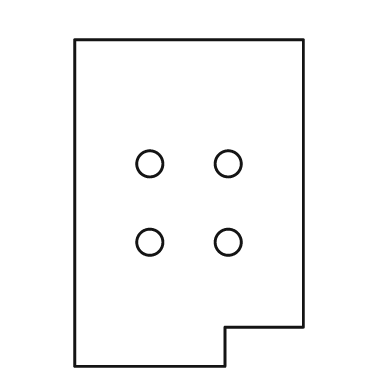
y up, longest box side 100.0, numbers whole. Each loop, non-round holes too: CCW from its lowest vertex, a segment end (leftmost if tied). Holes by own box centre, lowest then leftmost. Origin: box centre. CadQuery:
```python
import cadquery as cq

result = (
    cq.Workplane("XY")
    .moveTo(-35.0, -50.0)
    .lineTo(11.0, -50.0)
    .lineTo(11.0, -38.0)
    .lineTo(35.0, -38.0)
    .lineTo(35.0, 50.0)
    .lineTo(-35.0, 50.0)
    .close()
    .moveTo(-12.0, -12.0)
    .circle(4.0)
    .moveTo(12.0, -12.0)
    .circle(4.0)
    .moveTo(-12.0, 12.0)
    .circle(4.0)
    .moveTo(12.0, 12.0)
    .circle(4.0)
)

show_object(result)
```